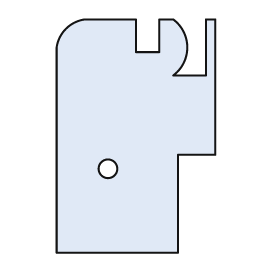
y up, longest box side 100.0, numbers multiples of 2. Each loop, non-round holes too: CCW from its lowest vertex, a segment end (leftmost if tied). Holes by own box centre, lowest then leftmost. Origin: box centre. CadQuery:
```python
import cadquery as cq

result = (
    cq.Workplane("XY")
    .moveTo(-34.0, -50.0)
    .lineTo(18.0, -50.0)
    .lineTo(18.0, -8.0)
    .lineTo(34.0, -8.0)
    .lineTo(34.0, 50.0)
    .lineTo(30.0, 50.0)
    .lineTo(30.0, 26.0)
    .lineTo(16.0, 26.0)
    .threePointArc((22.0, 38.0), (16.0, 50.0))
    .lineTo(10.0, 50.0)
    .lineTo(10.0, 36.0)
    .lineTo(0.0, 36.0)
    .lineTo(0.0, 50.0)
    .lineTo(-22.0, 50.0)
    .threePointArc((-30.0, 46.0), (-34.0, 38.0))
    .close()
    .moveTo(-12.0, -14.0)
    .circle(4.0)
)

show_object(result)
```